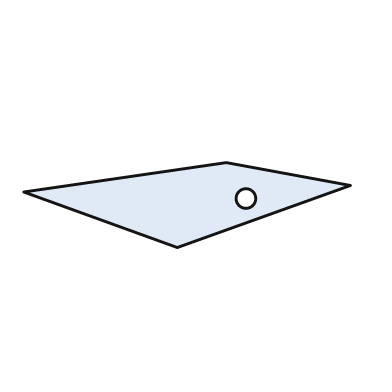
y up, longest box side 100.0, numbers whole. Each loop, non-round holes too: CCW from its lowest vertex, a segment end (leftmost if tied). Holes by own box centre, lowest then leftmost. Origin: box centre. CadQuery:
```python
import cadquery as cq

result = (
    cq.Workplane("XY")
    .moveTo(-3.0, -13.0)
    .lineTo(50.0, 6.0)
    .lineTo(12.0, 13.0)
    .lineTo(-50.0, 4.0)
    .close()
    .moveTo(18.0, 2.0)
    .circle(3.0)
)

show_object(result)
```